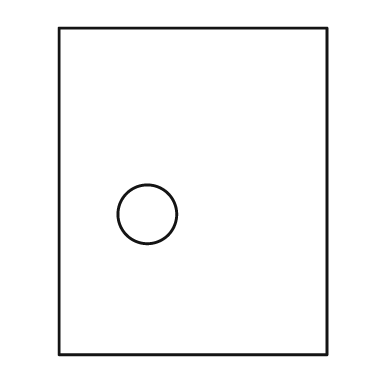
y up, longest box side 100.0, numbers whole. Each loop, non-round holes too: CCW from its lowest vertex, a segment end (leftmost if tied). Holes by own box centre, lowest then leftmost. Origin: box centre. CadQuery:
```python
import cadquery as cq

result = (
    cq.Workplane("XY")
    .moveTo(-41.0, -50.0)
    .lineTo(41.0, -50.0)
    .lineTo(41.0, 50.0)
    .lineTo(-41.0, 50.0)
    .close()
    .moveTo(-14.0, -7.0)
    .circle(9.0)
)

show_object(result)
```